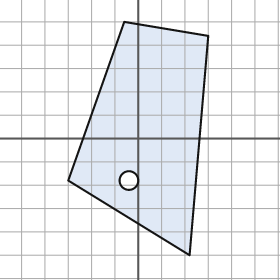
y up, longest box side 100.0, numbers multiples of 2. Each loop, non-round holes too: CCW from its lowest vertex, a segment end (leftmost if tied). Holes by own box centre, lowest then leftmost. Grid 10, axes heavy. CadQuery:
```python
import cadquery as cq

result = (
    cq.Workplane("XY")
    .moveTo(22.0, -50.0)
    .lineTo(30.0, 44.0)
    .lineTo(-6.0, 50.0)
    .lineTo(-30.0, -18.0)
    .close()
    .moveTo(-4.0, -18.0)
    .circle(4.0)
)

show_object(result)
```